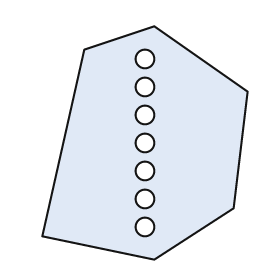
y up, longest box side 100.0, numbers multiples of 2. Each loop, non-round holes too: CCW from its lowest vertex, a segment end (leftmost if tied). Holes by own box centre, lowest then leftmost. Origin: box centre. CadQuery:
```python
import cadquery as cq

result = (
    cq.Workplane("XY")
    .moveTo(4.0, -50.0)
    .lineTo(38.0, -28.0)
    .lineTo(44.0, 22.0)
    .lineTo(4.0, 50.0)
    .lineTo(-26.0, 40.0)
    .lineTo(-44.0, -40.0)
    .close()
    .moveTo(0.0, -36.0)
    .circle(4.0)
    .moveTo(0.0, -24.0)
    .circle(4.0)
    .moveTo(0.0, -12.0)
    .circle(4.0)
    .moveTo(0.0, 0.0)
    .circle(4.0)
    .moveTo(0.0, 12.0)
    .circle(4.0)
    .moveTo(0.0, 24.0)
    .circle(4.0)
    .moveTo(0.0, 36.0)
    .circle(4.0)
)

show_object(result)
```